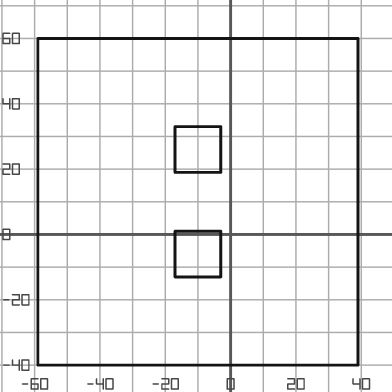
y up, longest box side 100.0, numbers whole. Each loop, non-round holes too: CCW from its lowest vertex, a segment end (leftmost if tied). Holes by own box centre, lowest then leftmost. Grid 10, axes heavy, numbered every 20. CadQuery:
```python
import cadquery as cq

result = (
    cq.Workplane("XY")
    .moveTo(-59.0, -40.0)
    .lineTo(39.0, -40.0)
    .lineTo(39.0, 60.0)
    .lineTo(-59.0, 60.0)
    .close()
    .moveTo(-17.0, -13.0)
    .lineTo(-3.0, -13.0)
    .lineTo(-3.0, 1.0)
    .lineTo(-17.0, 1.0)
    .close()
    .moveTo(-17.0, 19.0)
    .lineTo(-3.0, 19.0)
    .lineTo(-3.0, 33.0)
    .lineTo(-17.0, 33.0)
    .close()
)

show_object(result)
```